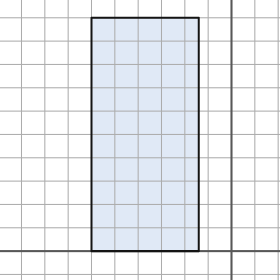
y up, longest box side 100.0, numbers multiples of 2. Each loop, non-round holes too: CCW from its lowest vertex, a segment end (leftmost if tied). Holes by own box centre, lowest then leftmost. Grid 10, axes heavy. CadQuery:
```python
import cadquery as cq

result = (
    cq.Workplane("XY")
    .moveTo(-60.0, 0.0)
    .lineTo(-14.0, 0.0)
    .lineTo(-14.0, 100.0)
    .lineTo(-60.0, 100.0)
    .close()
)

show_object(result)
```